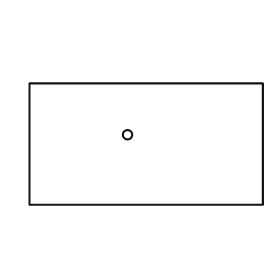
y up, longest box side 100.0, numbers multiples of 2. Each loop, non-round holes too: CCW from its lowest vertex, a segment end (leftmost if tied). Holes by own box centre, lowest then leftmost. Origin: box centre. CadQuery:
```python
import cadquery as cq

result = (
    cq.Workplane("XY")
    .moveTo(-50.0, -26.0)
    .lineTo(50.0, -26.0)
    .lineTo(50.0, 26.0)
    .lineTo(-50.0, 26.0)
    .close()
    .moveTo(-8.0, 4.0)
    .circle(2.0)
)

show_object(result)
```